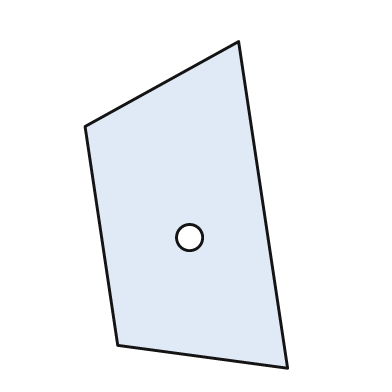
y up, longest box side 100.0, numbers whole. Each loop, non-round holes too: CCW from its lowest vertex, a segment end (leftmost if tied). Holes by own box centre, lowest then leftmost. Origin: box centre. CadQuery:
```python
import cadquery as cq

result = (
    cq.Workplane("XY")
    .moveTo(31.0, -50.0)
    .lineTo(16.0, 50.0)
    .lineTo(-31.0, 24.0)
    .lineTo(-21.0, -43.0)
    .close()
    .moveTo(1.0, -10.0)
    .circle(4.0)
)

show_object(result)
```